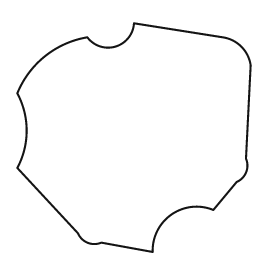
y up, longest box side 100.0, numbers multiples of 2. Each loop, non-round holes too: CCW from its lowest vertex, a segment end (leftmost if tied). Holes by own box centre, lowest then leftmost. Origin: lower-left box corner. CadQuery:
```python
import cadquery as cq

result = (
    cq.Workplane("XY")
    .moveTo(58.0, 0.0)
    .threePointArc((66.0, 16.0), (84.0, 18.0))
    .lineTo(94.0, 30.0)
    .threePointArc((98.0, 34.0), (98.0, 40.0))
    .lineTo(100.0, 80.0)
    .threePointArc((96.0, 88.0), (88.0, 92.0))
    .lineTo(50.0, 98.0)
    .threePointArc((42.0, 88.0), (30.0, 92.0))
    .threePointArc((12.0, 84.0), (0.0, 68.0))
    .threePointArc((4.0, 52.0), (0.0, 36.0))
    .lineTo(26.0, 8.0)
    .threePointArc((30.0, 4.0), (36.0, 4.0))
    .close()
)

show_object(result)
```